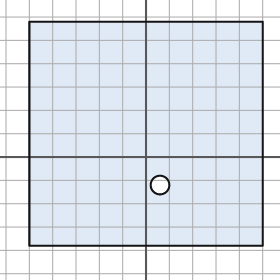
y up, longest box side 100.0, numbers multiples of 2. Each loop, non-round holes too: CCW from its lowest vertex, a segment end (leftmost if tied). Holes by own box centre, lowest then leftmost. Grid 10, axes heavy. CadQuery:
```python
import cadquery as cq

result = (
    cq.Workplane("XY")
    .moveTo(-50.0, -38.0)
    .lineTo(50.0, -38.0)
    .lineTo(50.0, 58.0)
    .lineTo(-50.0, 58.0)
    .close()
    .moveTo(6.0, -12.0)
    .circle(4.0)
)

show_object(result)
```